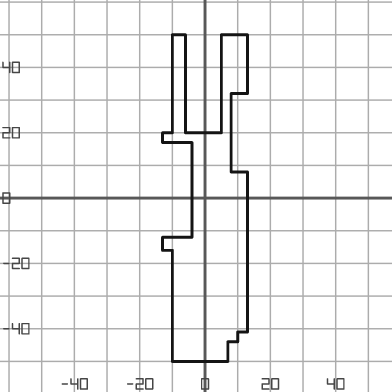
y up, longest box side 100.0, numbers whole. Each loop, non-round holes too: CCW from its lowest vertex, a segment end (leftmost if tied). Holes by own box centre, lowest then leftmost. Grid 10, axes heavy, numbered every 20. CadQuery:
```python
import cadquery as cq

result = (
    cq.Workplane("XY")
    .moveTo(-10.0, -50.0)
    .lineTo(7.0, -50.0)
    .lineTo(7.0, -44.0)
    .lineTo(10.0, -44.0)
    .lineTo(10.0, -41.0)
    .lineTo(13.0, -41.0)
    .lineTo(13.0, 8.0)
    .lineTo(8.0, 8.0)
    .lineTo(8.0, 32.0)
    .lineTo(13.0, 32.0)
    .lineTo(13.0, 50.0)
    .lineTo(5.0, 50.0)
    .lineTo(5.0, 20.0)
    .lineTo(-6.0, 20.0)
    .lineTo(-6.0, 50.0)
    .lineTo(-10.0, 50.0)
    .lineTo(-10.0, 20.0)
    .lineTo(-13.0, 20.0)
    .lineTo(-13.0, 17.0)
    .lineTo(-4.0, 17.0)
    .lineTo(-4.0, -12.0)
    .lineTo(-13.0, -12.0)
    .lineTo(-13.0, -16.0)
    .lineTo(-10.0, -16.0)
    .close()
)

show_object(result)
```